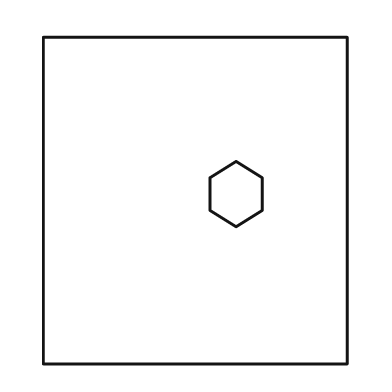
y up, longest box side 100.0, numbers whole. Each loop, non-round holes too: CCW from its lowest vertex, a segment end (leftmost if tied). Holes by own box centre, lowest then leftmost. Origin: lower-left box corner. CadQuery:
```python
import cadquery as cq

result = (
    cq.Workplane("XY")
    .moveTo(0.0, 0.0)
    .lineTo(93.0, 0.0)
    .lineTo(93.0, 100.0)
    .lineTo(0.0, 100.0)
    .close()
    .moveTo(59.0, 42.0)
    .lineTo(67.0, 47.0)
    .lineTo(67.0, 57.0)
    .lineTo(59.0, 62.0)
    .lineTo(51.0, 57.0)
    .lineTo(51.0, 47.0)
    .close()
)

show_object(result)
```